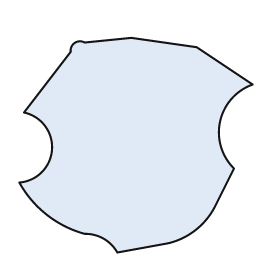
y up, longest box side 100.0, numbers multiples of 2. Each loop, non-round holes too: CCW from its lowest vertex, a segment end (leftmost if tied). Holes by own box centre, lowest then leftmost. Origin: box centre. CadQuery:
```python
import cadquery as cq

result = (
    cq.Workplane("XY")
    .moveTo(-8.0, -46.0)
    .lineTo(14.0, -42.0)
    .threePointArc((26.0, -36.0), (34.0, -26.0))
    .lineTo(42.0, -10.0)
    .threePointArc((36.0, 10.0), (50.0, 26.0))
    .lineTo(26.0, 42.0)
    .lineTo(-2.0, 46.0)
    .lineTo(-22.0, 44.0)
    .threePointArc((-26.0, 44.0), (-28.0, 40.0))
    .lineTo(-48.0, 14.0)
    .threePointArc((-36.0, -2.0), (-50.0, -16.0))
    .threePointArc((-38.0, -30.0), (-22.0, -38.0))
    .threePointArc((-14.0, -40.0), (-8.0, -46.0))
    .close()
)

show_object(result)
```